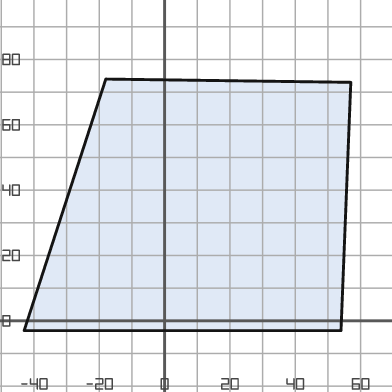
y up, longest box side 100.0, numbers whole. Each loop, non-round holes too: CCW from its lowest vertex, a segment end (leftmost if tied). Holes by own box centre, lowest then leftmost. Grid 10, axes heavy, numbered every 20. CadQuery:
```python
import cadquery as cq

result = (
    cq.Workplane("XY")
    .moveTo(-43.0, -3.0)
    .lineTo(54.0, -3.0)
    .lineTo(57.0, 73.0)
    .lineTo(-18.0, 74.0)
    .close()
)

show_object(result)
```